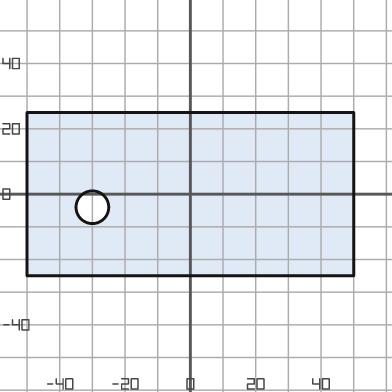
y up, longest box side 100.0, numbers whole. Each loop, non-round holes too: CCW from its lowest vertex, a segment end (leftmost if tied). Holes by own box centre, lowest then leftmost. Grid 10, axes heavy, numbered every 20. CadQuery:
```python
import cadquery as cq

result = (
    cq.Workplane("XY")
    .moveTo(-50.0, -25.0)
    .lineTo(50.0, -25.0)
    .lineTo(50.0, 25.0)
    .lineTo(-50.0, 25.0)
    .close()
    .moveTo(-30.0, -4.0)
    .circle(5.0)
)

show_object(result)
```